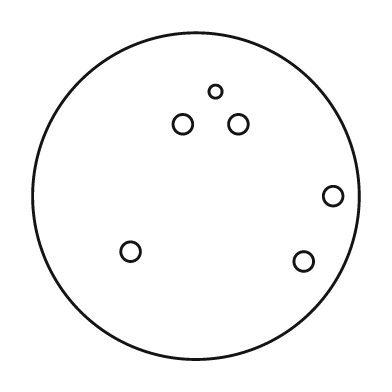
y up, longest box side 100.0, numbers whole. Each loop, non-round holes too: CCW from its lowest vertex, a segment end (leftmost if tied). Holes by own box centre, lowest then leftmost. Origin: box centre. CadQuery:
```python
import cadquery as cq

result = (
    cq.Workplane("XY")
    .moveTo(0.0, 0.0)
    .circle(50.0)
    .moveTo(33.0, -20.0)
    .circle(3.0)
    .moveTo(-20.0, -17.0)
    .circle(3.0)
    .moveTo(42.0, 0.0)
    .circle(3.0)
    .moveTo(-4.0, 22.0)
    .circle(3.0)
    .moveTo(13.0, 22.0)
    .circle(3.0)
    .moveTo(6.0, 32.0)
    .circle(2.0)
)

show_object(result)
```